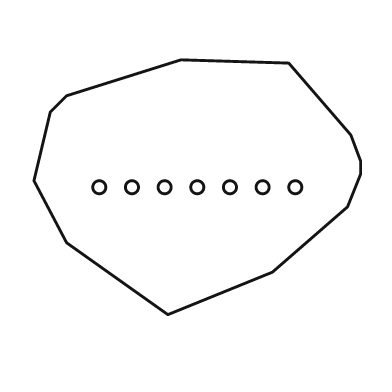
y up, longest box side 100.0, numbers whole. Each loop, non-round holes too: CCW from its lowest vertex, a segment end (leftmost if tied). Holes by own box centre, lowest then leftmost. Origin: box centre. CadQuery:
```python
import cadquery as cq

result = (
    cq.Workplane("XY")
    .moveTo(-9.0, -39.0)
    .lineTo(23.0, -26.0)
    .lineTo(46.0, -6.0)
    .lineTo(50.0, 4.0)
    .lineTo(50.0, 8.0)
    .lineTo(47.0, 16.0)
    .lineTo(28.0, 38.0)
    .lineTo(-5.0, 39.0)
    .lineTo(-40.0, 28.0)
    .lineTo(-45.0, 23.0)
    .lineTo(-50.0, 2.0)
    .lineTo(-40.0, -17.0)
    .close()
    .moveTo(-30.0, 0.0)
    .circle(2.0)
    .moveTo(-20.0, 0.0)
    .circle(2.0)
    .moveTo(-10.0, 0.0)
    .circle(2.0)
    .moveTo(0.0, 0.0)
    .circle(2.0)
    .moveTo(10.0, 0.0)
    .circle(2.0)
    .moveTo(20.0, 0.0)
    .circle(2.0)
    .moveTo(30.0, 0.0)
    .circle(2.0)
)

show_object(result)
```